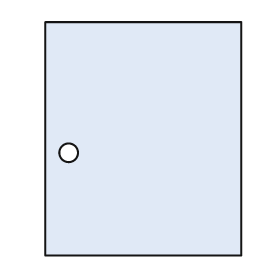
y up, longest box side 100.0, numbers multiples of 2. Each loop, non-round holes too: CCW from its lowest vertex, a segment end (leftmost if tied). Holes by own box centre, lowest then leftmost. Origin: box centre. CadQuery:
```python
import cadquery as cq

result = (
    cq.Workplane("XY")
    .moveTo(-42.0, -50.0)
    .lineTo(42.0, -50.0)
    .lineTo(42.0, 50.0)
    .lineTo(-42.0, 50.0)
    .close()
    .moveTo(-32.0, -6.0)
    .circle(4.0)
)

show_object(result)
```